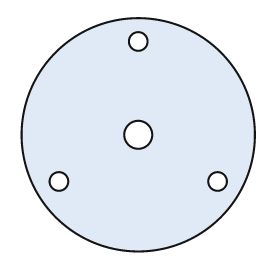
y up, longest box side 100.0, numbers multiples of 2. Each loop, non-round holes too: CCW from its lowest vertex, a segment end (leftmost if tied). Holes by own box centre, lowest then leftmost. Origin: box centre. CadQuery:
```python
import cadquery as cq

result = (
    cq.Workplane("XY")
    .moveTo(0.0, 0.0)
    .circle(50.0)
    .moveTo(-34.0, -20.0)
    .circle(4.0)
    .moveTo(34.0, -20.0)
    .circle(4.0)
    .moveTo(0.0, 0.0)
    .circle(6.0)
    .moveTo(0.0, 40.0)
    .circle(4.0)
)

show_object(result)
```